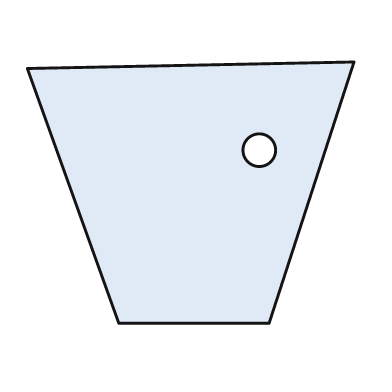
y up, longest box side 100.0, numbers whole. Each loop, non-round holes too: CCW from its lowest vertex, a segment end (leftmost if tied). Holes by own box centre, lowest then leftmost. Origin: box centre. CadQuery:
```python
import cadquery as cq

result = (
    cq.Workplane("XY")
    .moveTo(-22.0, -40.0)
    .lineTo(24.0, -40.0)
    .lineTo(50.0, 40.0)
    .lineTo(-50.0, 38.0)
    .close()
    .moveTo(21.0, 13.0)
    .circle(5.0)
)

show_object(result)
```